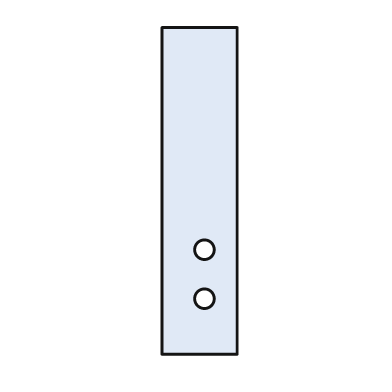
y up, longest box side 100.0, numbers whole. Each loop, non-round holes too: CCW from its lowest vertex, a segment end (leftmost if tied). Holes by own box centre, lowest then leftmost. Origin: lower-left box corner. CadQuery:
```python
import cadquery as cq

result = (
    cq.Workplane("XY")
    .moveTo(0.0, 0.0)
    .lineTo(23.0, 0.0)
    .lineTo(23.0, 100.0)
    .lineTo(0.0, 100.0)
    .close()
    .moveTo(13.0, 17.0)
    .circle(3.0)
    .moveTo(13.0, 32.0)
    .circle(3.0)
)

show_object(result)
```